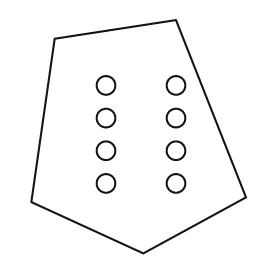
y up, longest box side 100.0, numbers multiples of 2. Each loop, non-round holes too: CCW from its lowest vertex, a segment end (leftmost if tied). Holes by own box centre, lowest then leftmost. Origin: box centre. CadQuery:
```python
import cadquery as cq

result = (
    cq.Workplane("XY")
    .moveTo(2.0, -50.0)
    .lineTo(46.0, -26.0)
    .lineTo(16.0, 50.0)
    .lineTo(-36.0, 42.0)
    .lineTo(-46.0, -28.0)
    .close()
    .moveTo(-14.0, -20.0)
    .circle(4.0)
    .moveTo(16.0, -20.0)
    .circle(4.0)
    .moveTo(-14.0, -6.0)
    .circle(4.0)
    .moveTo(16.0, -6.0)
    .circle(4.0)
    .moveTo(-14.0, 8.0)
    .circle(4.0)
    .moveTo(16.0, 8.0)
    .circle(4.0)
    .moveTo(-14.0, 22.0)
    .circle(4.0)
    .moveTo(16.0, 22.0)
    .circle(4.0)
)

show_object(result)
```